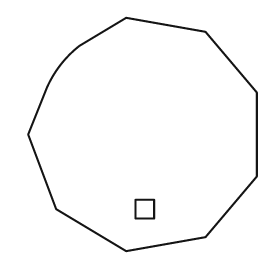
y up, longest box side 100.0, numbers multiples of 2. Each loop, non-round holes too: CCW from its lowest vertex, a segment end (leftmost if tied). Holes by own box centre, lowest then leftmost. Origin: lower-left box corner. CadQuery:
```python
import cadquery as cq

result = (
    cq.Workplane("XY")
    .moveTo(42.0, 0.0)
    .lineTo(76.0, 6.0)
    .lineTo(98.0, 32.0)
    .lineTo(98.0, 68.0)
    .lineTo(76.0, 94.0)
    .lineTo(42.0, 100.0)
    .lineTo(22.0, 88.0)
    .threePointArc((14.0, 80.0), (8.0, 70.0))
    .lineTo(0.0, 50.0)
    .lineTo(12.0, 18.0)
    .close()
    .moveTo(46.0, 14.0)
    .lineTo(54.0, 14.0)
    .lineTo(54.0, 22.0)
    .lineTo(46.0, 22.0)
    .close()
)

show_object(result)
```